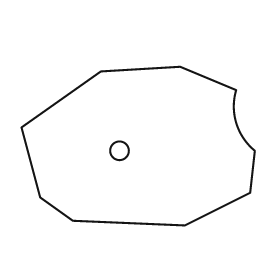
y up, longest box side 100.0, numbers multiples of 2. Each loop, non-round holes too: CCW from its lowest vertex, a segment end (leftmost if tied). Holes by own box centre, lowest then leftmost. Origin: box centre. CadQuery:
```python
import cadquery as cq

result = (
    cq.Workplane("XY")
    .moveTo(20.0, -34.0)
    .lineTo(48.0, -20.0)
    .lineTo(50.0, -2.0)
    .threePointArc((42.0, 10.0), (42.0, 24.0))
    .lineTo(18.0, 34.0)
    .lineTo(-16.0, 32.0)
    .lineTo(-50.0, 8.0)
    .lineTo(-42.0, -22.0)
    .lineTo(-28.0, -32.0)
    .close()
    .moveTo(-8.0, -2.0)
    .circle(4.0)
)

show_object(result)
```